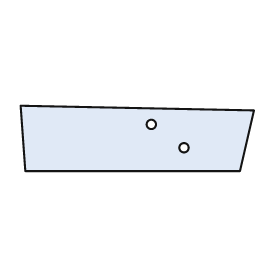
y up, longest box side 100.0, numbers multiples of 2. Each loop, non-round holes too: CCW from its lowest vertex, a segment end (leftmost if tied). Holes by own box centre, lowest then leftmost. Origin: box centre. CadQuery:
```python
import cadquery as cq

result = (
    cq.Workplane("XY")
    .moveTo(-48.0, -14.0)
    .lineTo(44.0, -14.0)
    .lineTo(50.0, 12.0)
    .lineTo(-50.0, 14.0)
    .close()
    .moveTo(20.0, -4.0)
    .circle(2.0)
    .moveTo(6.0, 6.0)
    .circle(2.0)
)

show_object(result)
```